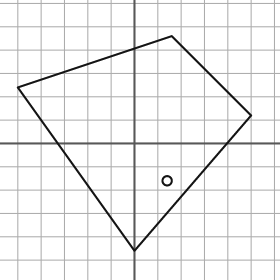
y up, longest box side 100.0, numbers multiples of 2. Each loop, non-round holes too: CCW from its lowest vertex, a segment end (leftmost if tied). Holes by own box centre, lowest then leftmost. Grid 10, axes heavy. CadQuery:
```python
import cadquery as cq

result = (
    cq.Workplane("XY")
    .moveTo(0.0, -46.0)
    .lineTo(50.0, 12.0)
    .lineTo(16.0, 46.0)
    .lineTo(-50.0, 24.0)
    .close()
    .moveTo(14.0, -16.0)
    .circle(2.0)
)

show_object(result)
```